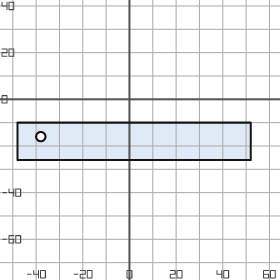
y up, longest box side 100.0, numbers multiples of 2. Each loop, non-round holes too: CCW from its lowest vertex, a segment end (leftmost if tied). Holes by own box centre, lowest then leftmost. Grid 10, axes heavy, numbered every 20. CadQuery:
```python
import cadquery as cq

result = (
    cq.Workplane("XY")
    .moveTo(-48.0, -26.0)
    .lineTo(52.0, -26.0)
    .lineTo(52.0, -10.0)
    .lineTo(-48.0, -10.0)
    .close()
    .moveTo(-38.0, -16.0)
    .circle(2.0)
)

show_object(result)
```